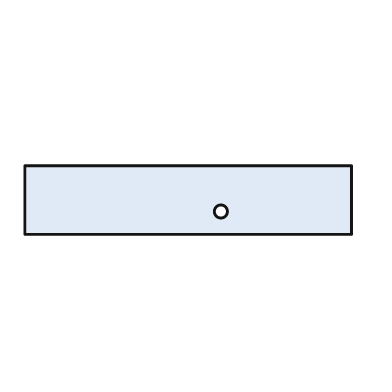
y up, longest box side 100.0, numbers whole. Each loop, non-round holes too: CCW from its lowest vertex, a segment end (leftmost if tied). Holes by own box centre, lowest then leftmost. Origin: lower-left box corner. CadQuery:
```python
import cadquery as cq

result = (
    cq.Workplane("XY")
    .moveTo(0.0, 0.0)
    .lineTo(100.0, 0.0)
    .lineTo(100.0, 21.0)
    .lineTo(0.0, 21.0)
    .close()
    .moveTo(60.0, 7.0)
    .circle(2.0)
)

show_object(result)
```